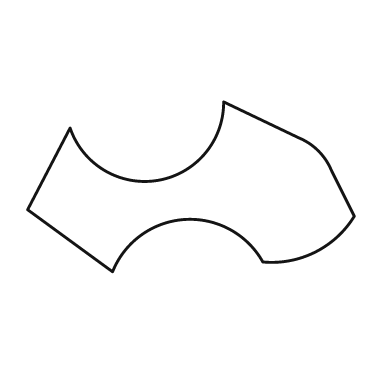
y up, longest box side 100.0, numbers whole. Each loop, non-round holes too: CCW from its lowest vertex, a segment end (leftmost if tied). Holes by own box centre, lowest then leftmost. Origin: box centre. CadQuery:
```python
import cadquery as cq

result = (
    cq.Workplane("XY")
    .moveTo(-24.0, -26.0)
    .threePointArc((-2.0, -10.0), (22.0, -23.0))
    .threePointArc((38.0, -20.0), (50.0, -9.0))
    .lineTo(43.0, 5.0)
    .threePointArc((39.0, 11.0), (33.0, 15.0))
    .lineTo(10.0, 26.0)
    .threePointArc((-10.0, 2.0), (-37.0, 18.0))
    .lineTo(-50.0, -7.0)
    .close()
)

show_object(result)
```